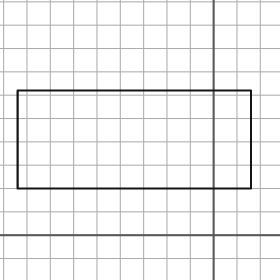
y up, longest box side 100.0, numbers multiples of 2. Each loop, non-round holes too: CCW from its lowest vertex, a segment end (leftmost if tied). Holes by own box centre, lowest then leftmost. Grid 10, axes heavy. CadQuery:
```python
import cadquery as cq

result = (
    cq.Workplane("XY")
    .moveTo(-84.0, 20.0)
    .lineTo(16.0, 20.0)
    .lineTo(16.0, 62.0)
    .lineTo(-84.0, 62.0)
    .close()
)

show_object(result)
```